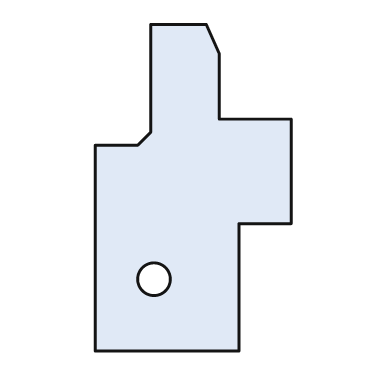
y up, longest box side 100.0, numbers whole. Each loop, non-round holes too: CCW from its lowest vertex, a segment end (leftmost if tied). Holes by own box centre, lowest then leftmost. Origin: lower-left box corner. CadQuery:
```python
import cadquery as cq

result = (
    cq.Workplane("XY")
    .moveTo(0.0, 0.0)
    .lineTo(44.0, 0.0)
    .lineTo(44.0, 39.0)
    .lineTo(60.0, 39.0)
    .lineTo(60.0, 71.0)
    .lineTo(38.0, 71.0)
    .lineTo(38.0, 91.0)
    .lineTo(34.0, 100.0)
    .lineTo(17.0, 100.0)
    .lineTo(17.0, 67.0)
    .lineTo(13.0, 63.0)
    .lineTo(0.0, 63.0)
    .close()
    .moveTo(18.0, 22.0)
    .circle(5.0)
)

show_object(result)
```